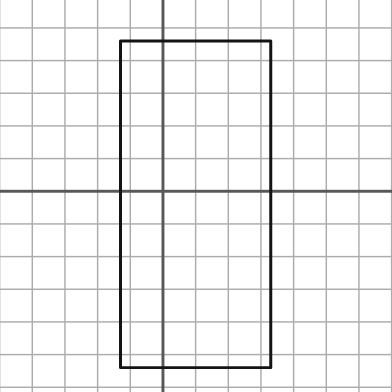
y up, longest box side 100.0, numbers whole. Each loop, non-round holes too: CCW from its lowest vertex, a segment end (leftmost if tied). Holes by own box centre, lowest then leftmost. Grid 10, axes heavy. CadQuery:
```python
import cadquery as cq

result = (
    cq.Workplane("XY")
    .moveTo(-13.0, -54.0)
    .lineTo(33.0, -54.0)
    .lineTo(33.0, 46.0)
    .lineTo(-13.0, 46.0)
    .close()
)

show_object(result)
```